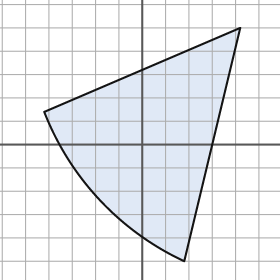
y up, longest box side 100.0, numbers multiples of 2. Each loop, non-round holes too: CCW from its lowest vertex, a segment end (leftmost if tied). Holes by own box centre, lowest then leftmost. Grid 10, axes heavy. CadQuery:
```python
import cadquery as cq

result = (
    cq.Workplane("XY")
    .moveTo(18.0, -50.0)
    .lineTo(42.0, 50.0)
    .lineTo(-42.0, 14.0)
    .threePointArc((-18.0, -24.0), (18.0, -50.0))
    .close()
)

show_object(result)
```